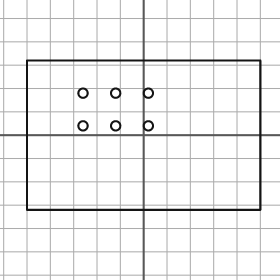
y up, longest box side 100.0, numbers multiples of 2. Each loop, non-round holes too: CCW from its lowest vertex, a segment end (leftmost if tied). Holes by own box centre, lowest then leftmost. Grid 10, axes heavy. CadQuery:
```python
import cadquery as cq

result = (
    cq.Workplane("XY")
    .moveTo(-50.0, -32.0)
    .lineTo(50.0, -32.0)
    .lineTo(50.0, 32.0)
    .lineTo(-50.0, 32.0)
    .close()
    .moveTo(-26.0, 4.0)
    .circle(2.0)
    .moveTo(-12.0, 4.0)
    .circle(2.0)
    .moveTo(2.0, 4.0)
    .circle(2.0)
    .moveTo(-26.0, 18.0)
    .circle(2.0)
    .moveTo(-12.0, 18.0)
    .circle(2.0)
    .moveTo(2.0, 18.0)
    .circle(2.0)
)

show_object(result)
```